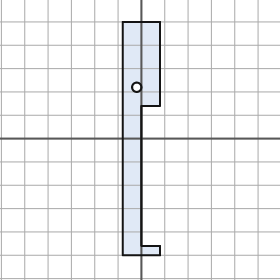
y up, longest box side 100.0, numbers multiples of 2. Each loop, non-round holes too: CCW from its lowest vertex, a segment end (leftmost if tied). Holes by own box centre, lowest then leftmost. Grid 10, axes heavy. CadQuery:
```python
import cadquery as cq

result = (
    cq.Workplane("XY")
    .moveTo(-8.0, -50.0)
    .lineTo(8.0, -50.0)
    .lineTo(8.0, -46.0)
    .lineTo(0.0, -46.0)
    .lineTo(0.0, 14.0)
    .lineTo(8.0, 14.0)
    .lineTo(8.0, 50.0)
    .lineTo(-8.0, 50.0)
    .close()
    .moveTo(-2.0, 22.0)
    .circle(2.0)
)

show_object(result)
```